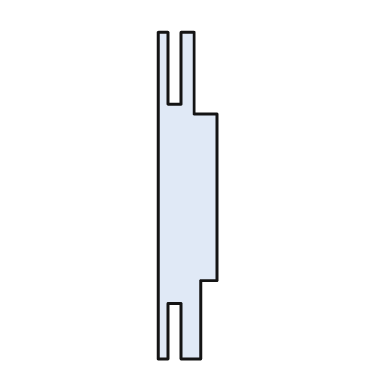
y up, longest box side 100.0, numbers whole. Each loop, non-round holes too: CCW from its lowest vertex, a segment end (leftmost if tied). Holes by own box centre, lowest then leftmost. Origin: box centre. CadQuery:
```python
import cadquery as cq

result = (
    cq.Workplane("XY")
    .moveTo(-9.0, -50.0)
    .lineTo(-6.0, -50.0)
    .lineTo(-6.0, -33.0)
    .lineTo(-2.0, -33.0)
    .lineTo(-2.0, -50.0)
    .lineTo(4.0, -50.0)
    .lineTo(4.0, -26.0)
    .lineTo(9.0, -26.0)
    .lineTo(9.0, 25.0)
    .lineTo(2.0, 25.0)
    .lineTo(2.0, 50.0)
    .lineTo(-2.0, 50.0)
    .lineTo(-2.0, 28.0)
    .lineTo(-6.0, 28.0)
    .lineTo(-6.0, 50.0)
    .lineTo(-9.0, 50.0)
    .close()
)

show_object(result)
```